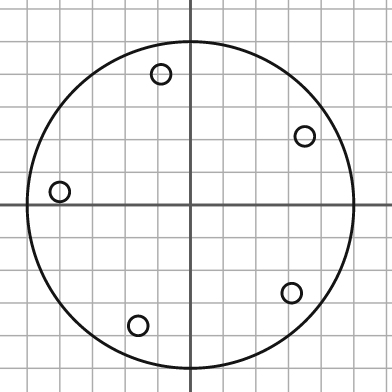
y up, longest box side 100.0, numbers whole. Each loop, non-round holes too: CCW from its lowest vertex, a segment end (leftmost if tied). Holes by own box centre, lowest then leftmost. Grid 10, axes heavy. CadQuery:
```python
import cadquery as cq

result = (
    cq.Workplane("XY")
    .moveTo(0.0, 0.0)
    .circle(50.0)
    .moveTo(-16.0, -37.0)
    .circle(3.0)
    .moveTo(31.0, -27.0)
    .circle(3.0)
    .moveTo(-40.0, 4.0)
    .circle(3.0)
    .moveTo(35.0, 21.0)
    .circle(3.0)
    .moveTo(-9.0, 40.0)
    .circle(3.0)
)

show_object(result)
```